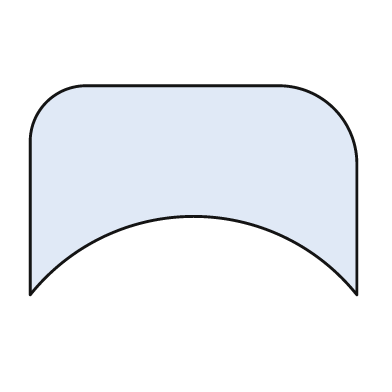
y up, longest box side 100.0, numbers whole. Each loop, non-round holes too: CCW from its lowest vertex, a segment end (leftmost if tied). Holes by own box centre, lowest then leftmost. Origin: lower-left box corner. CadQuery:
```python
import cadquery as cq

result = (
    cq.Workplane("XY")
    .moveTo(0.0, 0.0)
    .threePointArc((50.0, 24.0), (100.0, 0.0))
    .lineTo(100.0, 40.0)
    .threePointArc((93.0, 57.0), (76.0, 64.0))
    .lineTo(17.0, 64.0)
    .threePointArc((5.0, 59.0), (0.0, 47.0))
    .close()
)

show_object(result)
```